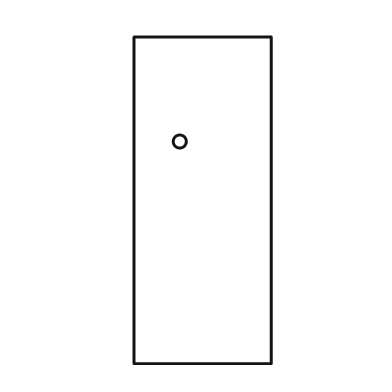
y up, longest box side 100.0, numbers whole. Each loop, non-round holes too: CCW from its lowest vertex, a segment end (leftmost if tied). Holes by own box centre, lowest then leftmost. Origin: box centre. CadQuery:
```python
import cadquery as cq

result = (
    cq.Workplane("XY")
    .moveTo(-21.0, -50.0)
    .lineTo(21.0, -50.0)
    .lineTo(21.0, 50.0)
    .lineTo(-21.0, 50.0)
    .close()
    .moveTo(-7.0, 18.0)
    .circle(2.0)
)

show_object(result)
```